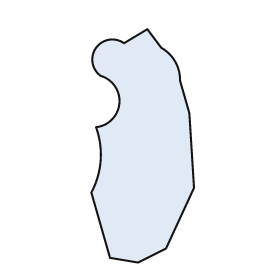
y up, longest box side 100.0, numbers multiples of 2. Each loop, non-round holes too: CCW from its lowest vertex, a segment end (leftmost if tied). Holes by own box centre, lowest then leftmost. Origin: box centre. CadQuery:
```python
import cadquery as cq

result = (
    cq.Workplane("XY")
    .moveTo(-2.0, -50.0)
    .lineTo(10.0, -44.0)
    .lineTo(22.0, -18.0)
    .lineTo(20.0, 14.0)
    .lineTo(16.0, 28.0)
    .threePointArc((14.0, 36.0), (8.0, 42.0))
    .lineTo(2.0, 50.0)
    .lineTo(-8.0, 44.0)
    .threePointArc((-20.0, 42.0), (-18.0, 30.0))
    .threePointArc((-10.0, 18.0), (-20.0, 8.0))
    .threePointArc((-18.0, -6.0), (-22.0, -20.0))
    .lineTo(-14.0, -48.0)
    .close()
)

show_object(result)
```